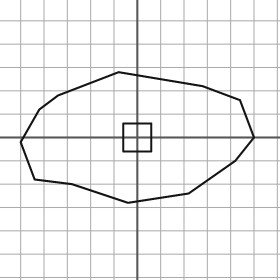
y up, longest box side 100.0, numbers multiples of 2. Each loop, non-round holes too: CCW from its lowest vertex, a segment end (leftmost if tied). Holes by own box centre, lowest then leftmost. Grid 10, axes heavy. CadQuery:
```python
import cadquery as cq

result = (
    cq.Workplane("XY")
    .moveTo(-4.0, -28.0)
    .lineTo(22.0, -24.0)
    .lineTo(42.0, -10.0)
    .lineTo(50.0, 0.0)
    .lineTo(44.0, 16.0)
    .lineTo(28.0, 22.0)
    .lineTo(-8.0, 28.0)
    .lineTo(-34.0, 18.0)
    .lineTo(-42.0, 12.0)
    .lineTo(-50.0, -2.0)
    .lineTo(-44.0, -18.0)
    .lineTo(-28.0, -20.0)
    .close()
    .moveTo(-6.0, -6.0)
    .lineTo(6.0, -6.0)
    .lineTo(6.0, 6.0)
    .lineTo(-6.0, 6.0)
    .close()
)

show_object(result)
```